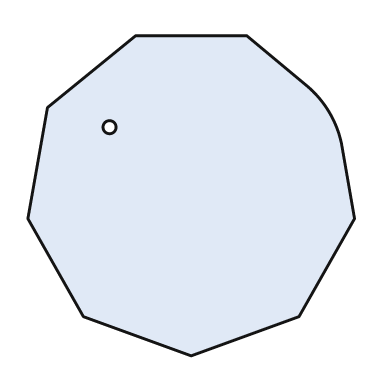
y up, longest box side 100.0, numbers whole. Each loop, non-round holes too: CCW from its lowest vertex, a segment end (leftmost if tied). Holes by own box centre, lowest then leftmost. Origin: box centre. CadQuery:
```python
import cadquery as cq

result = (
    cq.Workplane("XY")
    .moveTo(0.0, -49.0)
    .lineTo(33.0, -37.0)
    .lineTo(50.0, -7.0)
    .lineTo(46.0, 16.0)
    .threePointArc((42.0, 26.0), (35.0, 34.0))
    .lineTo(17.0, 49.0)
    .lineTo(-17.0, 49.0)
    .lineTo(-44.0, 27.0)
    .lineTo(-50.0, -7.0)
    .lineTo(-33.0, -37.0)
    .close()
    .moveTo(-25.0, 21.0)
    .circle(2.0)
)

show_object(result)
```